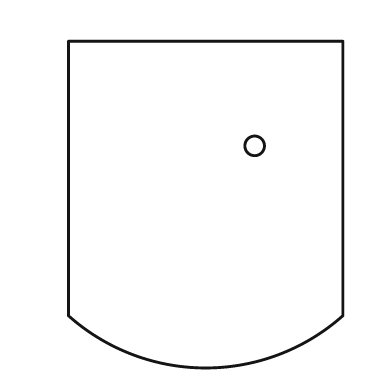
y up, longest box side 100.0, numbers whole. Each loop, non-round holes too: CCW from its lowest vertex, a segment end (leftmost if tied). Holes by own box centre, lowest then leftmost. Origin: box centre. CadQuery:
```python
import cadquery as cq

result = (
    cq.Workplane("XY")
    .moveTo(-42.0, -34.0)
    .threePointArc((0.0, -50.0), (42.0, -34.0))
    .lineTo(42.0, 50.0)
    .lineTo(-42.0, 50.0)
    .close()
    .moveTo(15.0, 18.0)
    .circle(3.0)
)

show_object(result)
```